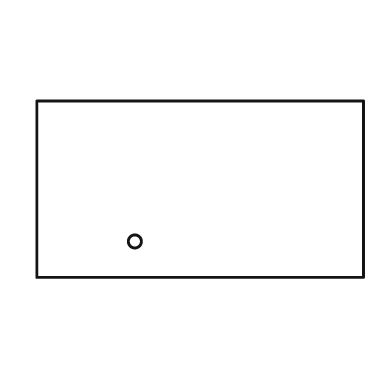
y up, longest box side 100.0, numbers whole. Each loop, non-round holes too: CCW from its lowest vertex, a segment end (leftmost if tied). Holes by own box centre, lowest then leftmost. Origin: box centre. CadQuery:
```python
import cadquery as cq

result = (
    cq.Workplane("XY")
    .moveTo(-50.0, -27.0)
    .lineTo(50.0, -27.0)
    .lineTo(50.0, 27.0)
    .lineTo(-50.0, 27.0)
    .close()
    .moveTo(-20.0, -16.0)
    .circle(2.0)
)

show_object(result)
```